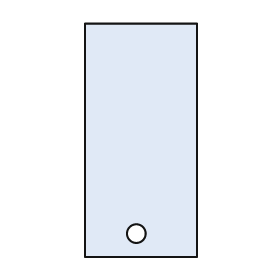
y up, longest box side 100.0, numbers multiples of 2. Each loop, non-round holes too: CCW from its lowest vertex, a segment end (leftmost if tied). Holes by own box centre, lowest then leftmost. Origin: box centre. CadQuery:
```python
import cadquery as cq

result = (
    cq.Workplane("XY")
    .moveTo(-24.0, -50.0)
    .lineTo(24.0, -50.0)
    .lineTo(24.0, 50.0)
    .lineTo(-24.0, 50.0)
    .close()
    .moveTo(-2.0, -40.0)
    .circle(4.0)
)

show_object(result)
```